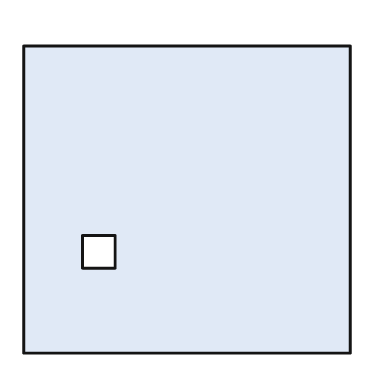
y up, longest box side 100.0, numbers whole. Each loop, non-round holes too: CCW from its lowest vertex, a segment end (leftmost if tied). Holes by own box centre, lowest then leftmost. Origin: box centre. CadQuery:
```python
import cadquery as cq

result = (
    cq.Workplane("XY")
    .moveTo(-50.0, -47.0)
    .lineTo(50.0, -47.0)
    .lineTo(50.0, 47.0)
    .lineTo(-50.0, 47.0)
    .close()
    .moveTo(-32.0, -21.0)
    .lineTo(-22.0, -21.0)
    .lineTo(-22.0, -11.0)
    .lineTo(-32.0, -11.0)
    .close()
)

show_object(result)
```